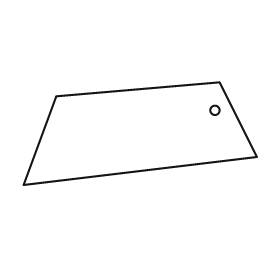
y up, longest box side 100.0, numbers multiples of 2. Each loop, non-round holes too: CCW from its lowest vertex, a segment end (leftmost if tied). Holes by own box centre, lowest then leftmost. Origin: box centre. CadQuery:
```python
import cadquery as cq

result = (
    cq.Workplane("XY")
    .moveTo(-50.0, -22.0)
    .lineTo(50.0, -10.0)
    .lineTo(34.0, 22.0)
    .lineTo(-36.0, 16.0)
    .close()
    .moveTo(32.0, 10.0)
    .circle(2.0)
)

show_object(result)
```